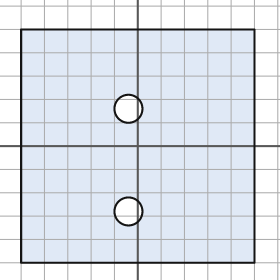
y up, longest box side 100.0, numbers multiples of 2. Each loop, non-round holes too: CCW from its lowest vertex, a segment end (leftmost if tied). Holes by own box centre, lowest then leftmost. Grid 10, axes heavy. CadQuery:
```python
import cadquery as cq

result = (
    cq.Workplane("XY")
    .moveTo(-50.0, -50.0)
    .lineTo(50.0, -50.0)
    .lineTo(50.0, 50.0)
    .lineTo(-50.0, 50.0)
    .close()
    .moveTo(-4.0, -28.0)
    .circle(6.0)
    .moveTo(-4.0, 16.0)
    .circle(6.0)
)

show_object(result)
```